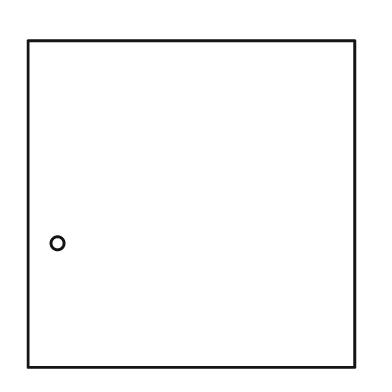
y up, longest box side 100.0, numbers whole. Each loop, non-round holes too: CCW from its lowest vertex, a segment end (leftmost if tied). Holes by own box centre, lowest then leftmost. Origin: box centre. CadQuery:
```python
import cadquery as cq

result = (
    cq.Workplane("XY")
    .moveTo(-50.0, -50.0)
    .lineTo(50.0, -50.0)
    .lineTo(50.0, 50.0)
    .lineTo(-50.0, 50.0)
    .close()
    .moveTo(-41.0, -12.0)
    .circle(2.0)
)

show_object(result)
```